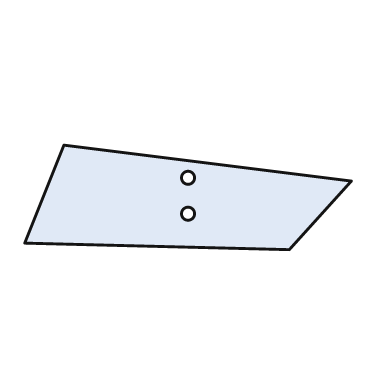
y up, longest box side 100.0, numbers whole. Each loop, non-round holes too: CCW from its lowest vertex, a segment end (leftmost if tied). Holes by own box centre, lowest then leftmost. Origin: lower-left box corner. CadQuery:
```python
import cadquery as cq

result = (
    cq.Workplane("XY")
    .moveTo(81.0, 0.0)
    .lineTo(100.0, 21.0)
    .lineTo(12.0, 32.0)
    .lineTo(0.0, 2.0)
    .close()
    .moveTo(50.0, 11.0)
    .circle(2.0)
    .moveTo(50.0, 22.0)
    .circle(2.0)
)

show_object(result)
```